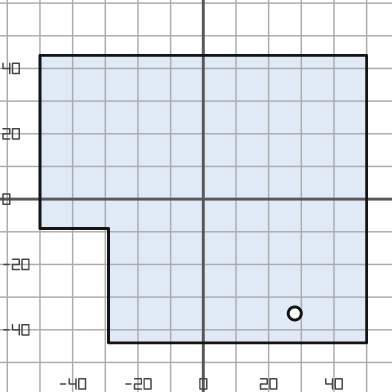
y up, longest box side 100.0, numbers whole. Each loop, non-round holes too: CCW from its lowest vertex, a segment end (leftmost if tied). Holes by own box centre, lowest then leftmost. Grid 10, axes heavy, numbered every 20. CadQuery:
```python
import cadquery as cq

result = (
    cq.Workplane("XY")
    .moveTo(-29.0, -44.0)
    .lineTo(50.0, -44.0)
    .lineTo(50.0, 44.0)
    .lineTo(-50.0, 44.0)
    .lineTo(-50.0, -9.0)
    .lineTo(-29.0, -9.0)
    .close()
    .moveTo(28.0, -35.0)
    .circle(2.0)
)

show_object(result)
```